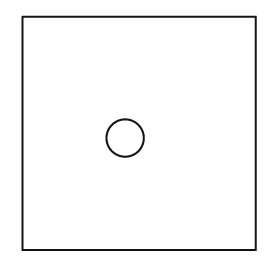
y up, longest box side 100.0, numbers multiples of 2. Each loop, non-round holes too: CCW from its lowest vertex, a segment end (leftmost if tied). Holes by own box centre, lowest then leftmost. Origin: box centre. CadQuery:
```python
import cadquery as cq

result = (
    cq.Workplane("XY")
    .moveTo(-50.0, -50.0)
    .lineTo(50.0, -50.0)
    .lineTo(50.0, 50.0)
    .lineTo(-50.0, 50.0)
    .close()
    .moveTo(-6.0, -2.0)
    .circle(8.0)
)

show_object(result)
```